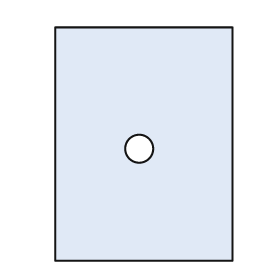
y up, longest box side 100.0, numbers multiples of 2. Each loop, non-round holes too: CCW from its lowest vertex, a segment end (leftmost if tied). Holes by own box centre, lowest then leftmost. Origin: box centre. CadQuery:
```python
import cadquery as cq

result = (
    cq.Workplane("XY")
    .moveTo(-38.0, -50.0)
    .lineTo(38.0, -50.0)
    .lineTo(38.0, 50.0)
    .lineTo(-38.0, 50.0)
    .close()
    .moveTo(-2.0, -2.0)
    .circle(6.0)
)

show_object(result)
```